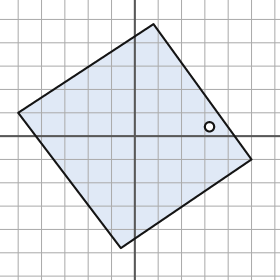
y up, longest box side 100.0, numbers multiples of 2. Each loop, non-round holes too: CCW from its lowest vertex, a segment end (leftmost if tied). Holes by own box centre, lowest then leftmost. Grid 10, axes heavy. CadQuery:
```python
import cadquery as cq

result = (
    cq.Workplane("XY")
    .moveTo(-6.0, -48.0)
    .lineTo(50.0, -10.0)
    .lineTo(8.0, 48.0)
    .lineTo(-50.0, 10.0)
    .close()
    .moveTo(32.0, 4.0)
    .circle(2.0)
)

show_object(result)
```